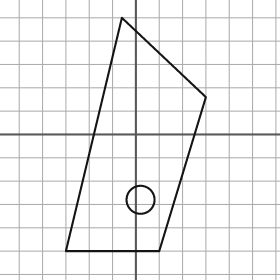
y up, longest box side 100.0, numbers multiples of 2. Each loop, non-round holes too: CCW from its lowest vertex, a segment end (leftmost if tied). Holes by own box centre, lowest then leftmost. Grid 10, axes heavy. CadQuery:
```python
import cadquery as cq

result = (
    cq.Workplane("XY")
    .moveTo(-30.0, -50.0)
    .lineTo(10.0, -50.0)
    .lineTo(30.0, 16.0)
    .lineTo(-6.0, 50.0)
    .close()
    .moveTo(2.0, -28.0)
    .circle(6.0)
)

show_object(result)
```